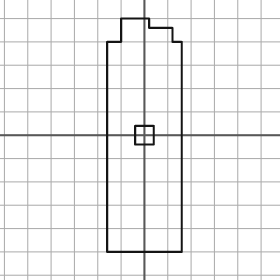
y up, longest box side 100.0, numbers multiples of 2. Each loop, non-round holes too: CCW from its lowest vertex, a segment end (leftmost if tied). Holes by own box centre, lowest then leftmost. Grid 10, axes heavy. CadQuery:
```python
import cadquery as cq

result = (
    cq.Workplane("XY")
    .moveTo(-16.0, -50.0)
    .lineTo(16.0, -50.0)
    .lineTo(16.0, 40.0)
    .lineTo(12.0, 40.0)
    .lineTo(12.0, 46.0)
    .lineTo(2.0, 46.0)
    .lineTo(2.0, 50.0)
    .lineTo(-10.0, 50.0)
    .lineTo(-10.0, 40.0)
    .lineTo(-16.0, 40.0)
    .close()
    .moveTo(-4.0, -4.0)
    .lineTo(4.0, -4.0)
    .lineTo(4.0, 4.0)
    .lineTo(-4.0, 4.0)
    .close()
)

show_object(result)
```